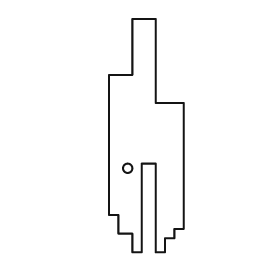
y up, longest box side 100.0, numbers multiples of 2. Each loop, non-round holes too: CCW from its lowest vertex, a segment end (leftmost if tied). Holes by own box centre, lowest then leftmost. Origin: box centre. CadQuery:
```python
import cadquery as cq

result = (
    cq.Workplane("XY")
    .moveTo(-6.0, -50.0)
    .lineTo(-2.0, -50.0)
    .lineTo(-2.0, -12.0)
    .lineTo(4.0, -12.0)
    .lineTo(4.0, -50.0)
    .lineTo(8.0, -50.0)
    .lineTo(8.0, -44.0)
    .lineTo(12.0, -44.0)
    .lineTo(12.0, -40.0)
    .lineTo(16.0, -40.0)
    .lineTo(16.0, 14.0)
    .lineTo(4.0, 14.0)
    .lineTo(4.0, 50.0)
    .lineTo(-6.0, 50.0)
    .lineTo(-6.0, 26.0)
    .lineTo(-16.0, 26.0)
    .lineTo(-16.0, -34.0)
    .lineTo(-12.0, -34.0)
    .lineTo(-12.0, -42.0)
    .lineTo(-6.0, -42.0)
    .close()
    .moveTo(-8.0, -14.0)
    .circle(2.0)
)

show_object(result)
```